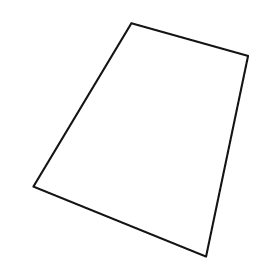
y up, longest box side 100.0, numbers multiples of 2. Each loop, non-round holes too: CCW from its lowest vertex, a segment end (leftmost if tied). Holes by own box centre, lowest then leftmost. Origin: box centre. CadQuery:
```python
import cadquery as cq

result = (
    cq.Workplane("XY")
    .moveTo(28.0, -50.0)
    .lineTo(46.0, 36.0)
    .lineTo(-4.0, 50.0)
    .lineTo(-46.0, -20.0)
    .close()
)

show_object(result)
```